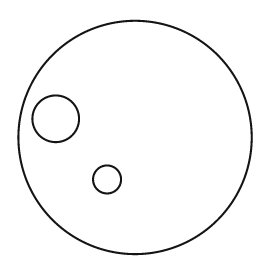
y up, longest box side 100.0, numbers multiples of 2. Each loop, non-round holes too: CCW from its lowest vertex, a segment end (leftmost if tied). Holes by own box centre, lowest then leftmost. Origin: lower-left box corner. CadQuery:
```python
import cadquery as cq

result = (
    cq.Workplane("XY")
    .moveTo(50.0, 50.0)
    .circle(50.0)
    .moveTo(38.0, 32.0)
    .circle(6.0)
    .moveTo(16.0, 58.0)
    .circle(10.0)
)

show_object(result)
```